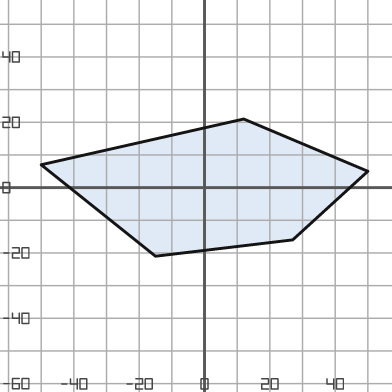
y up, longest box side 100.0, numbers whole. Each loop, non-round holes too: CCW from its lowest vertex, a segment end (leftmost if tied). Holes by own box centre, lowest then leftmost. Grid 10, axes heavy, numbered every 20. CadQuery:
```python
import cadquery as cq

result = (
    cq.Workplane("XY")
    .moveTo(-15.0, -21.0)
    .lineTo(27.0, -16.0)
    .lineTo(50.0, 5.0)
    .lineTo(12.0, 21.0)
    .lineTo(-50.0, 7.0)
    .close()
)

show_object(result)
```